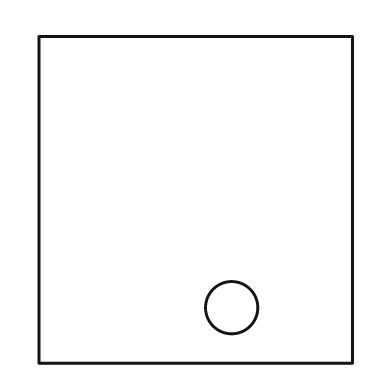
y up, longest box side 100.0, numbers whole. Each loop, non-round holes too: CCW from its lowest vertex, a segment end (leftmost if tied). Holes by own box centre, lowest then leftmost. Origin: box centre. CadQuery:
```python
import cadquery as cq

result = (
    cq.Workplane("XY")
    .moveTo(-48.0, -50.0)
    .lineTo(48.0, -50.0)
    .lineTo(48.0, 50.0)
    .lineTo(-48.0, 50.0)
    .close()
    .moveTo(11.0, -33.0)
    .circle(8.0)
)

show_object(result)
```